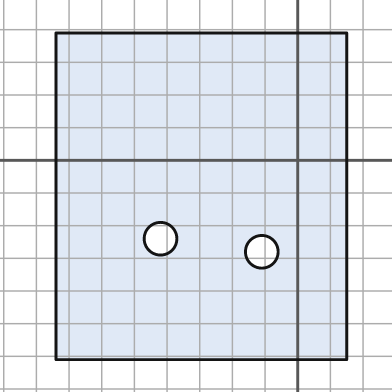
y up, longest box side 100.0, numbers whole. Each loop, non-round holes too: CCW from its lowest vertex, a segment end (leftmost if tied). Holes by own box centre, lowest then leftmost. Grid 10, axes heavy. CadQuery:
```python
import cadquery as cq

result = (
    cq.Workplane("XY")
    .moveTo(-74.0, -61.0)
    .lineTo(15.0, -61.0)
    .lineTo(15.0, 39.0)
    .lineTo(-74.0, 39.0)
    .close()
    .moveTo(-11.0, -28.0)
    .circle(5.0)
    .moveTo(-42.0, -24.0)
    .circle(5.0)
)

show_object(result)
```